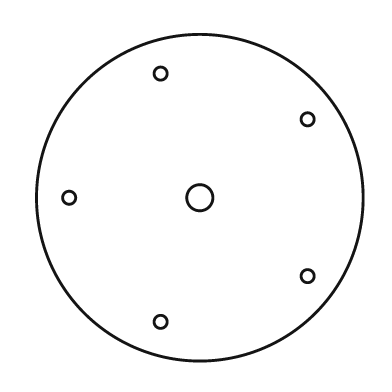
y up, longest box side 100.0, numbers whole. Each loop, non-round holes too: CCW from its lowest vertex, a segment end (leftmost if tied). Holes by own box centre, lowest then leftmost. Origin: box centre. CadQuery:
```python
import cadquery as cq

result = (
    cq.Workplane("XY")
    .moveTo(0.0, 0.0)
    .circle(50.0)
    .moveTo(-12.0, -38.0)
    .circle(2.0)
    .moveTo(33.0, -24.0)
    .circle(2.0)
    .moveTo(-40.0, 0.0)
    .circle(2.0)
    .moveTo(0.0, 0.0)
    .circle(4.0)
    .moveTo(33.0, 24.0)
    .circle(2.0)
    .moveTo(-12.0, 38.0)
    .circle(2.0)
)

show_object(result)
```